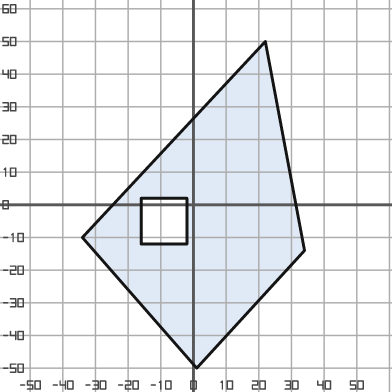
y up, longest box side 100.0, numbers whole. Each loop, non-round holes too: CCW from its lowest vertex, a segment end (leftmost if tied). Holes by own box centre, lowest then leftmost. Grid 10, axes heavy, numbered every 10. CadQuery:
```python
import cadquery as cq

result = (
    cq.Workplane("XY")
    .moveTo(1.0, -50.0)
    .lineTo(34.0, -14.0)
    .lineTo(22.0, 50.0)
    .lineTo(-34.0, -10.0)
    .close()
    .moveTo(-16.0, -12.0)
    .lineTo(-2.0, -12.0)
    .lineTo(-2.0, 2.0)
    .lineTo(-16.0, 2.0)
    .close()
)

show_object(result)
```